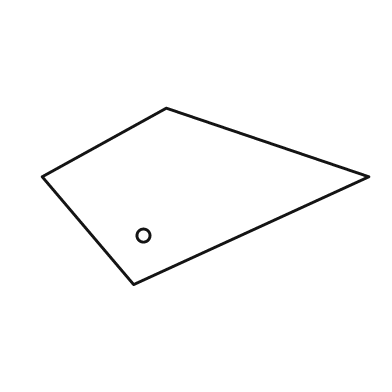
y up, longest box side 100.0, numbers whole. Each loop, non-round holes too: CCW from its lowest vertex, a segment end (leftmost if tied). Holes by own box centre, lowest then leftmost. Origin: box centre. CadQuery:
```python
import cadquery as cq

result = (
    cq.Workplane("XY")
    .moveTo(-22.0, -27.0)
    .lineTo(50.0, 6.0)
    .lineTo(-12.0, 27.0)
    .lineTo(-50.0, 6.0)
    .close()
    .moveTo(-19.0, -12.0)
    .circle(2.0)
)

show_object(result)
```